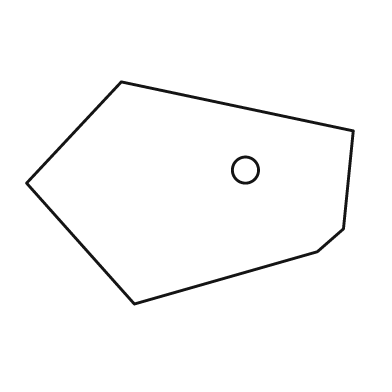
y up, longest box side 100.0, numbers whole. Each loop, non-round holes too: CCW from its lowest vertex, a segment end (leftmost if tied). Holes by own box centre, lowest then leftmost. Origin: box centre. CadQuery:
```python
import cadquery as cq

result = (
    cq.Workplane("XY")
    .moveTo(-17.0, -34.0)
    .lineTo(39.0, -18.0)
    .lineTo(47.0, -11.0)
    .lineTo(50.0, 19.0)
    .lineTo(-21.0, 34.0)
    .lineTo(-50.0, 3.0)
    .close()
    .moveTo(17.0, 7.0)
    .circle(4.0)
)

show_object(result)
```